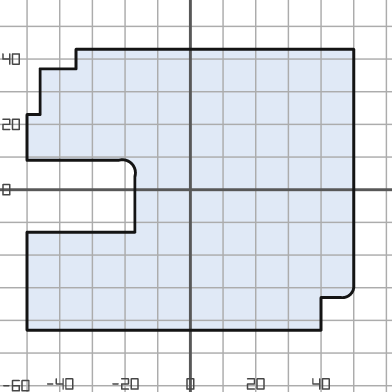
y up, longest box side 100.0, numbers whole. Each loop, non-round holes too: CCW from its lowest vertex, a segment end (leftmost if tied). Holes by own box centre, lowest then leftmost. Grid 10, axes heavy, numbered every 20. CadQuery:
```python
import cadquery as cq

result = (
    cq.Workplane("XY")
    .moveTo(-50.0, -43.0)
    .lineTo(40.0, -43.0)
    .lineTo(40.0, -33.0)
    .lineTo(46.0, -33.0)
    .threePointArc((49.0, -32.0), (50.0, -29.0))
    .lineTo(50.0, 43.0)
    .lineTo(-35.0, 43.0)
    .lineTo(-35.0, 37.0)
    .lineTo(-46.0, 37.0)
    .lineTo(-46.0, 23.0)
    .lineTo(-50.0, 23.0)
    .lineTo(-50.0, 9.0)
    .lineTo(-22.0, 9.0)
    .threePointArc((-18.0, 8.0), (-17.0, 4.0))
    .lineTo(-17.0, -13.0)
    .lineTo(-50.0, -13.0)
    .close()
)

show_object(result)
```